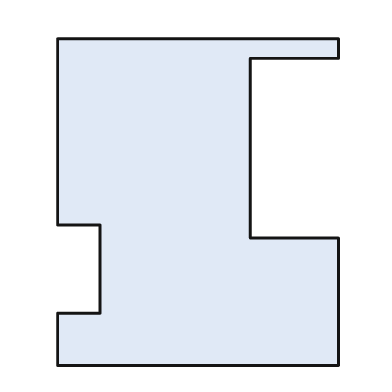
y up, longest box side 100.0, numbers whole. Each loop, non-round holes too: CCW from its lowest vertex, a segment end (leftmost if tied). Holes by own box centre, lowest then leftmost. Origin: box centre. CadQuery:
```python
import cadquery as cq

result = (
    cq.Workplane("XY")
    .moveTo(-43.0, -50.0)
    .lineTo(43.0, -50.0)
    .lineTo(43.0, -11.0)
    .lineTo(16.0, -11.0)
    .lineTo(16.0, 44.0)
    .lineTo(43.0, 44.0)
    .lineTo(43.0, 50.0)
    .lineTo(-43.0, 50.0)
    .lineTo(-43.0, -7.0)
    .lineTo(-30.0, -7.0)
    .lineTo(-30.0, -34.0)
    .lineTo(-43.0, -34.0)
    .close()
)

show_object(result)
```